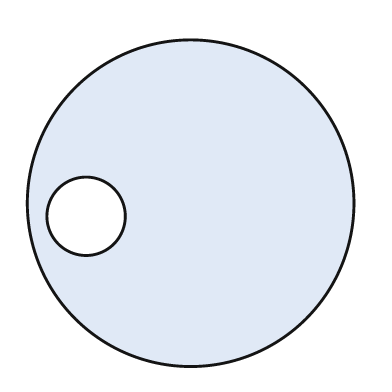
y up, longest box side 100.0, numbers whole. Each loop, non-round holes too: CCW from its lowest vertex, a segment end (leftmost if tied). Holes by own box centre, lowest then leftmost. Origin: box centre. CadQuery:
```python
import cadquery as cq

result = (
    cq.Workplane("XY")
    .moveTo(0.0, 0.0)
    .circle(50.0)
    .moveTo(-32.0, -4.0)
    .circle(12.0)
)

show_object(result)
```